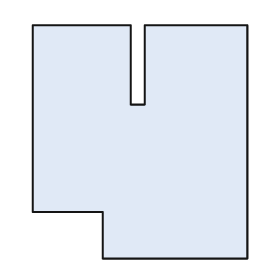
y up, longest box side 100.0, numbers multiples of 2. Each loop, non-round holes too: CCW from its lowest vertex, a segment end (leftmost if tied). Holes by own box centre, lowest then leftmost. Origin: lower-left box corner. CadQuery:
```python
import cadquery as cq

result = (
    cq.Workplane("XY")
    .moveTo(30.0, 0.0)
    .lineTo(92.0, 0.0)
    .lineTo(92.0, 100.0)
    .lineTo(48.0, 100.0)
    .lineTo(48.0, 66.0)
    .lineTo(42.0, 66.0)
    .lineTo(42.0, 100.0)
    .lineTo(0.0, 100.0)
    .lineTo(0.0, 20.0)
    .lineTo(30.0, 20.0)
    .close()
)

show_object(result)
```